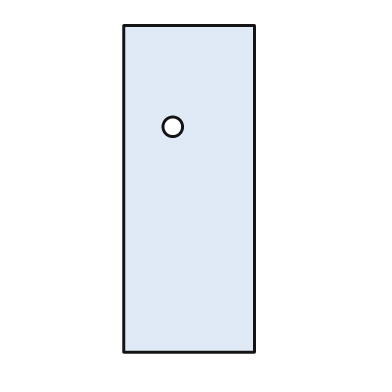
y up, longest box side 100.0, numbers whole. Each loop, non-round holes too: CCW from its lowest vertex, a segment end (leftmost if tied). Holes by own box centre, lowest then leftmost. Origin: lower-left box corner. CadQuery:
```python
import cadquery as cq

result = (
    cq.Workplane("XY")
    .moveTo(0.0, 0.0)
    .lineTo(40.0, 0.0)
    .lineTo(40.0, 100.0)
    .lineTo(0.0, 100.0)
    .close()
    .moveTo(15.0, 69.0)
    .circle(3.0)
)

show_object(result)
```